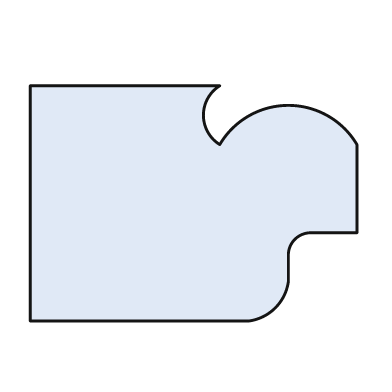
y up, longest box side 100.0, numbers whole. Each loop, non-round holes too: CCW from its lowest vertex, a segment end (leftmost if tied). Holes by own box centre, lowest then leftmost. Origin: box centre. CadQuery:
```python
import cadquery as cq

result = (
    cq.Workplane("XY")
    .moveTo(-50.0, -36.0)
    .lineTo(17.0, -36.0)
    .threePointArc((25.0, -32.0), (29.0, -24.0))
    .lineTo(29.0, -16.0)
    .threePointArc((31.0, -11.0), (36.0, -9.0))
    .lineTo(50.0, -9.0)
    .lineTo(50.0, 18.0)
    .threePointArc((29.0, 30.0), (8.0, 18.0))
    .threePointArc((3.0, 27.0), (8.0, 36.0))
    .lineTo(-50.0, 36.0)
    .close()
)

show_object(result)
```